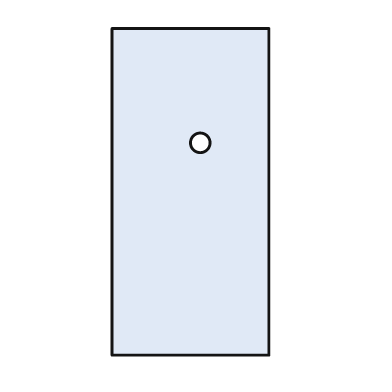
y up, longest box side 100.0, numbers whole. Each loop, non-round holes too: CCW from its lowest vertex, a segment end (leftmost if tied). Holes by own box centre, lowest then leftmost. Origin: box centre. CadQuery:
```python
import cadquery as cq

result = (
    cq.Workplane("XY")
    .moveTo(-24.0, -50.0)
    .lineTo(24.0, -50.0)
    .lineTo(24.0, 50.0)
    .lineTo(-24.0, 50.0)
    .close()
    .moveTo(3.0, 15.0)
    .circle(3.0)
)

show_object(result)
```